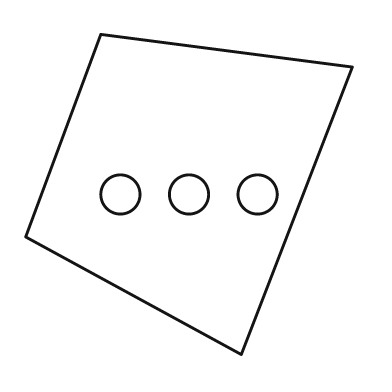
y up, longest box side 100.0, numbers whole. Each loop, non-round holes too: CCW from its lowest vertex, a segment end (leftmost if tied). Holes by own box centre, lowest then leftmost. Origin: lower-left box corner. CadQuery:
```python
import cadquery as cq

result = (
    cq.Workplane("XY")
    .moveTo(66.0, 0.0)
    .lineTo(100.0, 88.0)
    .lineTo(23.0, 98.0)
    .lineTo(0.0, 36.0)
    .close()
    .moveTo(29.0, 49.0)
    .circle(6.0)
    .moveTo(50.0, 49.0)
    .circle(6.0)
    .moveTo(71.0, 49.0)
    .circle(6.0)
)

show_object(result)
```